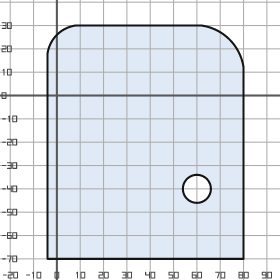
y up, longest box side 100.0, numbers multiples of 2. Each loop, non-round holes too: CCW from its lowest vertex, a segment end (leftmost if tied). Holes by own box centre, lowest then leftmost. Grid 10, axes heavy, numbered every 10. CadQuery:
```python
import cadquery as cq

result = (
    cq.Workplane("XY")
    .moveTo(-4.0, -70.0)
    .lineTo(80.0, -70.0)
    .lineTo(80.0, 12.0)
    .threePointArc((74.0, 24.0), (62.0, 30.0))
    .lineTo(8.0, 30.0)
    .threePointArc((0.0, 26.0), (-4.0, 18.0))
    .close()
    .moveTo(60.0, -40.0)
    .circle(6.0)
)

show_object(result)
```